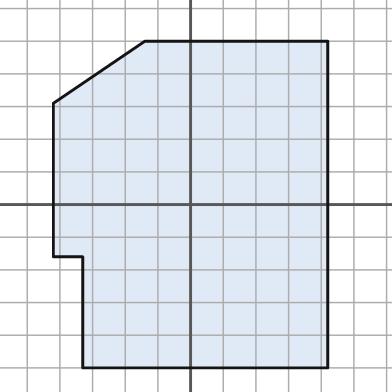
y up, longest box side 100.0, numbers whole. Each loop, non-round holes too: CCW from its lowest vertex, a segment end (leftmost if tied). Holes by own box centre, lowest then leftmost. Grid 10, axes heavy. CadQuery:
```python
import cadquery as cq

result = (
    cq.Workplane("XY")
    .moveTo(-33.0, -50.0)
    .lineTo(42.0, -50.0)
    .lineTo(42.0, 50.0)
    .lineTo(-14.0, 50.0)
    .lineTo(-42.0, 31.0)
    .lineTo(-42.0, -16.0)
    .lineTo(-33.0, -16.0)
    .close()
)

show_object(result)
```